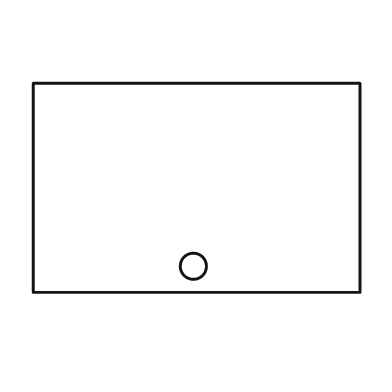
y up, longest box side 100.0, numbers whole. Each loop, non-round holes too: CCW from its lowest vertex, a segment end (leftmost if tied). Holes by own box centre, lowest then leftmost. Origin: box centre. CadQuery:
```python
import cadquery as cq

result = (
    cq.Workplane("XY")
    .moveTo(-50.0, -32.0)
    .lineTo(50.0, -32.0)
    .lineTo(50.0, 32.0)
    .lineTo(-50.0, 32.0)
    .close()
    .moveTo(-1.0, -24.0)
    .circle(4.0)
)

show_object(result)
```